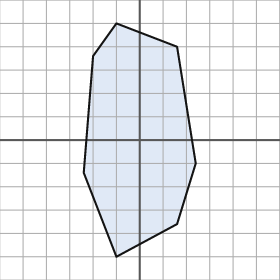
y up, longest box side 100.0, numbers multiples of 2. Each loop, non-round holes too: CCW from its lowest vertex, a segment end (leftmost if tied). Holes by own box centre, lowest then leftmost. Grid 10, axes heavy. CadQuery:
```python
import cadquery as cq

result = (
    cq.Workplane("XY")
    .moveTo(-10.0, -50.0)
    .lineTo(16.0, -36.0)
    .lineTo(24.0, -10.0)
    .lineTo(16.0, 40.0)
    .lineTo(-10.0, 50.0)
    .lineTo(-20.0, 36.0)
    .lineTo(-24.0, -14.0)
    .close()
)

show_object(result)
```